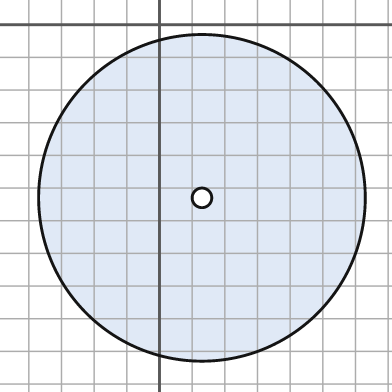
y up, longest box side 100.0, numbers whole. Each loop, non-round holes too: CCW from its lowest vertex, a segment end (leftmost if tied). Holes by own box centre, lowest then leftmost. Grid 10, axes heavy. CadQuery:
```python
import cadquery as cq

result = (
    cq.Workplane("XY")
    .moveTo(13.0, -53.0)
    .circle(50.0)
    .moveTo(13.0, -53.0)
    .circle(3.0)
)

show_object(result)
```